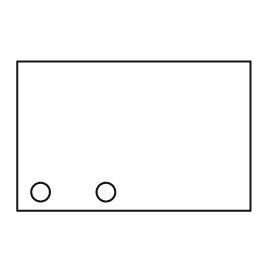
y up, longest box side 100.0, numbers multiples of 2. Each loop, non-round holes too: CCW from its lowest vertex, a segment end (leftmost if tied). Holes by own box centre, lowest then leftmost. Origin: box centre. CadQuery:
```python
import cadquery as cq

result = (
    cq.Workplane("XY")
    .moveTo(-50.0, -32.0)
    .lineTo(50.0, -32.0)
    .lineTo(50.0, 32.0)
    .lineTo(-50.0, 32.0)
    .close()
    .moveTo(-40.0, -24.0)
    .circle(4.0)
    .moveTo(-12.0, -24.0)
    .circle(4.0)
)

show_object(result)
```